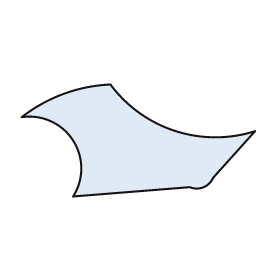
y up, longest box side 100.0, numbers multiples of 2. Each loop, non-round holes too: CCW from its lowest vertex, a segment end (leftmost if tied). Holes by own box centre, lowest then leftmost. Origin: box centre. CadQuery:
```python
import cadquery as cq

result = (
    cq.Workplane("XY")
    .moveTo(-28.0, -24.0)
    .lineTo(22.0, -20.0)
    .threePointArc((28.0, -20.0), (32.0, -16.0))
    .lineTo(50.0, 4.0)
    .threePointArc((16.0, 4.0), (-12.0, 24.0))
    .threePointArc((-32.0, 20.0), (-50.0, 10.0))
    .threePointArc((-28.0, 0.0), (-28.0, -24.0))
    .close()
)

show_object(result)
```